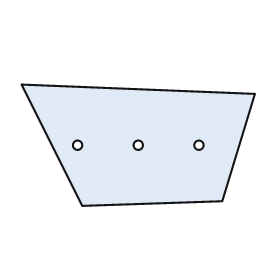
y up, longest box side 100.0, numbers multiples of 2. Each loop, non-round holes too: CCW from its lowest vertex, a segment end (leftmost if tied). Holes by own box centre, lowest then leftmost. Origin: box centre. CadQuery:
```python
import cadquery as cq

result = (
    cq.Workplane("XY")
    .moveTo(-24.0, -26.0)
    .lineTo(36.0, -24.0)
    .lineTo(50.0, 22.0)
    .lineTo(-50.0, 26.0)
    .close()
    .moveTo(-26.0, 0.0)
    .circle(2.0)
    .moveTo(0.0, 0.0)
    .circle(2.0)
    .moveTo(26.0, 0.0)
    .circle(2.0)
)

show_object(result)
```